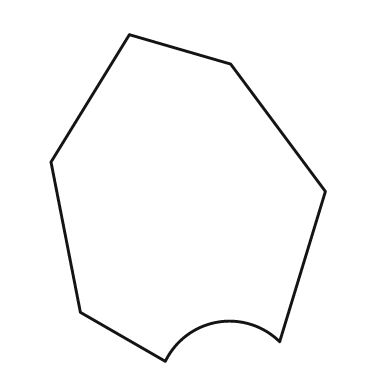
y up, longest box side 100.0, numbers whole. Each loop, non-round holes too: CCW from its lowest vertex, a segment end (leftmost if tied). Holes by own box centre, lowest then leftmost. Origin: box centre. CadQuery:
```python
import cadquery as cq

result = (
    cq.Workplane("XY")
    .moveTo(-7.0, -50.0)
    .threePointArc((9.0, -38.0), (28.0, -44.0))
    .lineTo(42.0, 2.0)
    .lineTo(13.0, 41.0)
    .lineTo(-18.0, 50.0)
    .lineTo(-42.0, 11.0)
    .lineTo(-33.0, -35.0)
    .close()
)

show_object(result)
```